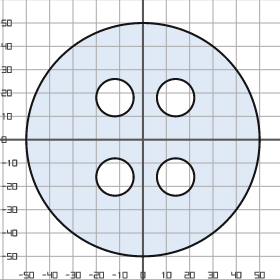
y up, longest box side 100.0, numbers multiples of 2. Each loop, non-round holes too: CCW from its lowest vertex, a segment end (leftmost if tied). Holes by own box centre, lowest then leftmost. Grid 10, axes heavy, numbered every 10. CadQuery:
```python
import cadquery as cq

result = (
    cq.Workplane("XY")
    .moveTo(0.0, 0.0)
    .circle(50.0)
    .moveTo(-12.0, -16.0)
    .circle(8.0)
    .moveTo(14.0, -16.0)
    .circle(8.0)
    .moveTo(-12.0, 18.0)
    .circle(8.0)
    .moveTo(14.0, 18.0)
    .circle(8.0)
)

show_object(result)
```